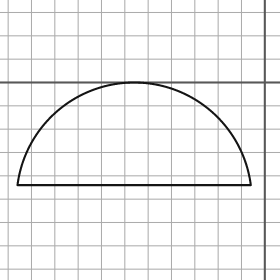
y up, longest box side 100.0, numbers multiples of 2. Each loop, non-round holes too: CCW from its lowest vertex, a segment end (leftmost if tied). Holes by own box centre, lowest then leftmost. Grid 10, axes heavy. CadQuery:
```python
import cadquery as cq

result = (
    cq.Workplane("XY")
    .moveTo(-106.0, -44.0)
    .lineTo(-6.0, -44.0)
    .threePointArc((-56.0, 0.0), (-106.0, -44.0))
    .close()
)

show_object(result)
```